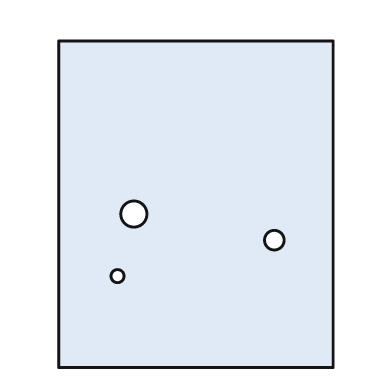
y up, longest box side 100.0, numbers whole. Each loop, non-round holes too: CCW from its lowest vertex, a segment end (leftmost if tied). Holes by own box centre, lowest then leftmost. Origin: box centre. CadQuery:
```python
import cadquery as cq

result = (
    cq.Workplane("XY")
    .moveTo(-42.0, -50.0)
    .lineTo(42.0, -50.0)
    .lineTo(42.0, 50.0)
    .lineTo(-42.0, 50.0)
    .close()
    .moveTo(-24.0, -22.0)
    .circle(2.0)
    .moveTo(24.0, -11.0)
    .circle(3.0)
    .moveTo(-19.0, -3.0)
    .circle(4.0)
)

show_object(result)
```